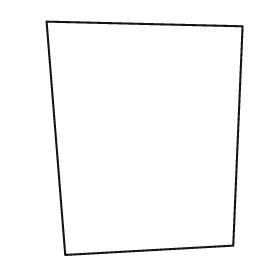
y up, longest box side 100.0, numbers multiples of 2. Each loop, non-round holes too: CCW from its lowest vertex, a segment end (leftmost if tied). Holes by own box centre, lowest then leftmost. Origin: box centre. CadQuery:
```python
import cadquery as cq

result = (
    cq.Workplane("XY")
    .moveTo(-34.0, -50.0)
    .lineTo(38.0, -46.0)
    .lineTo(42.0, 48.0)
    .lineTo(-42.0, 50.0)
    .close()
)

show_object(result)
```